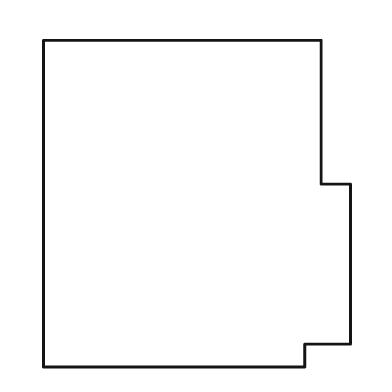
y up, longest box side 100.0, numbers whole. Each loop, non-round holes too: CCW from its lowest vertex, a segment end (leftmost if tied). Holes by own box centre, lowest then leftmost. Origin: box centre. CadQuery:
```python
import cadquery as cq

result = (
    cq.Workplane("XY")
    .moveTo(-47.0, -50.0)
    .lineTo(33.0, -50.0)
    .lineTo(33.0, -43.0)
    .lineTo(47.0, -43.0)
    .lineTo(47.0, 6.0)
    .lineTo(38.0, 6.0)
    .lineTo(38.0, 50.0)
    .lineTo(-47.0, 50.0)
    .close()
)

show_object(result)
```